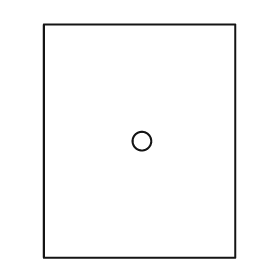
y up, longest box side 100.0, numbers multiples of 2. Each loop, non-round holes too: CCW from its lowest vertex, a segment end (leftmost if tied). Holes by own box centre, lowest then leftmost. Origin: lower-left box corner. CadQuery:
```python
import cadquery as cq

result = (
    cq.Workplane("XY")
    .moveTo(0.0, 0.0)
    .lineTo(82.0, 0.0)
    .lineTo(82.0, 100.0)
    .lineTo(0.0, 100.0)
    .close()
    .moveTo(42.0, 50.0)
    .circle(4.0)
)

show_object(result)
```